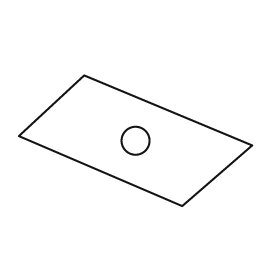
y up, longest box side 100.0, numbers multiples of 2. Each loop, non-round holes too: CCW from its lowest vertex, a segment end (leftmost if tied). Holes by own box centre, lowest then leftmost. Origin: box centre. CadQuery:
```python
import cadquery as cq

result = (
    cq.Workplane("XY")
    .moveTo(20.0, -28.0)
    .lineTo(50.0, -2.0)
    .lineTo(-22.0, 28.0)
    .lineTo(-50.0, 2.0)
    .close()
    .moveTo(0.0, 0.0)
    .circle(6.0)
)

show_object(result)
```